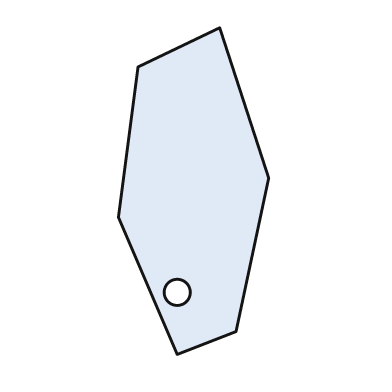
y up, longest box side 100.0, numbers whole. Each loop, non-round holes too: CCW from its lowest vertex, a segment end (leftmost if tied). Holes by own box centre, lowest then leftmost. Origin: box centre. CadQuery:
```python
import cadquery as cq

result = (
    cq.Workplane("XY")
    .moveTo(-5.0, -50.0)
    .lineTo(13.0, -43.0)
    .lineTo(23.0, 4.0)
    .lineTo(8.0, 50.0)
    .lineTo(-17.0, 38.0)
    .lineTo(-23.0, -8.0)
    .close()
    .moveTo(-5.0, -31.0)
    .circle(4.0)
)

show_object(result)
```